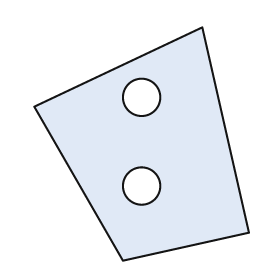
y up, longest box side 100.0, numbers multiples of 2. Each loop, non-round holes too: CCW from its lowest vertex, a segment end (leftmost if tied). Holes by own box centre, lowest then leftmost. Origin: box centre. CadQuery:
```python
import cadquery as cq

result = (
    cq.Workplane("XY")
    .moveTo(-8.0, -50.0)
    .lineTo(46.0, -38.0)
    .lineTo(26.0, 50.0)
    .lineTo(-46.0, 16.0)
    .close()
    .moveTo(0.0, -18.0)
    .circle(8.0)
    .moveTo(0.0, 20.0)
    .circle(8.0)
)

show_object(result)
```